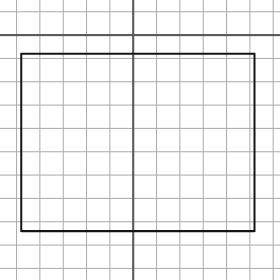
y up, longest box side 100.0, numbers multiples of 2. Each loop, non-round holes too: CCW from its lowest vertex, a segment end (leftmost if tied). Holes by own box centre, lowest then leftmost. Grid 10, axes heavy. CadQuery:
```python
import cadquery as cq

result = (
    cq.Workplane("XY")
    .moveTo(-48.0, -84.0)
    .lineTo(52.0, -84.0)
    .lineTo(52.0, -8.0)
    .lineTo(-48.0, -8.0)
    .close()
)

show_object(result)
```